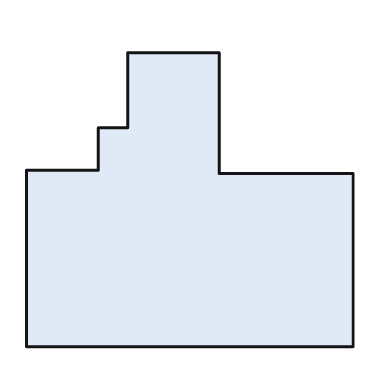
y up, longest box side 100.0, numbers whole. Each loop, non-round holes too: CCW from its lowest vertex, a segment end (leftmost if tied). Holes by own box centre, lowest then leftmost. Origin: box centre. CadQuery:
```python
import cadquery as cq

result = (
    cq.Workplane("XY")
    .moveTo(-50.0, -45.0)
    .lineTo(50.0, -45.0)
    .lineTo(50.0, 8.0)
    .lineTo(9.0, 8.0)
    .lineTo(9.0, 45.0)
    .lineTo(-19.0, 45.0)
    .lineTo(-19.0, 22.0)
    .lineTo(-28.0, 22.0)
    .lineTo(-28.0, 9.0)
    .lineTo(-50.0, 9.0)
    .close()
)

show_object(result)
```